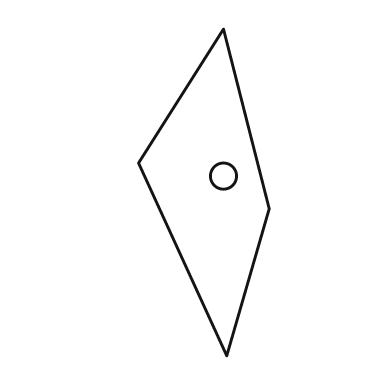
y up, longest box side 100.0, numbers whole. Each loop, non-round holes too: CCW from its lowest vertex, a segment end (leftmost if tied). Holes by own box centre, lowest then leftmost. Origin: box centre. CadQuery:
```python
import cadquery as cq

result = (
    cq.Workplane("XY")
    .moveTo(7.0, -50.0)
    .lineTo(20.0, -5.0)
    .lineTo(6.0, 50.0)
    .lineTo(-20.0, 9.0)
    .close()
    .moveTo(6.0, 5.0)
    .circle(4.0)
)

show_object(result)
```